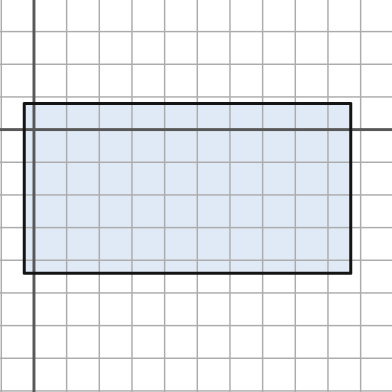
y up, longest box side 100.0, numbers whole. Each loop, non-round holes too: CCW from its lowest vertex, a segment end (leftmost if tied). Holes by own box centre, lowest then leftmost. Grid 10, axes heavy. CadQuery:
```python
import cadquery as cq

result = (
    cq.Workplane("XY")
    .moveTo(-3.0, -44.0)
    .lineTo(97.0, -44.0)
    .lineTo(97.0, 8.0)
    .lineTo(-3.0, 8.0)
    .close()
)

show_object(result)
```